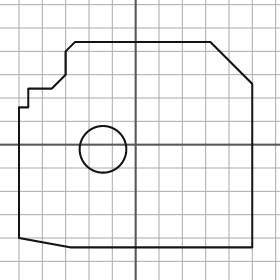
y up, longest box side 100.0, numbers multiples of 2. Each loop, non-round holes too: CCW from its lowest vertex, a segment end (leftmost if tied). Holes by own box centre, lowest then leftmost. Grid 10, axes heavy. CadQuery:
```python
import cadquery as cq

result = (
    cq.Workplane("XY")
    .moveTo(-28.0, -44.0)
    .lineTo(50.0, -44.0)
    .lineTo(50.0, 26.0)
    .lineTo(32.0, 44.0)
    .lineTo(-26.0, 44.0)
    .lineTo(-30.0, 40.0)
    .lineTo(-30.0, 30.0)
    .lineTo(-36.0, 24.0)
    .lineTo(-46.0, 24.0)
    .lineTo(-46.0, 16.0)
    .lineTo(-50.0, 16.0)
    .lineTo(-50.0, -40.0)
    .close()
    .moveTo(-14.0, -2.0)
    .circle(10.0)
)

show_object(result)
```